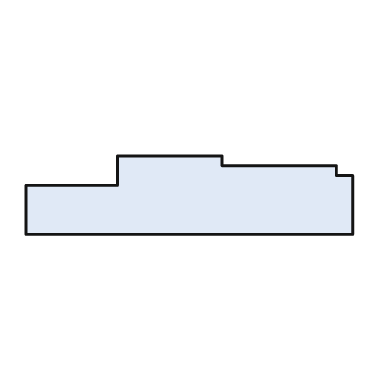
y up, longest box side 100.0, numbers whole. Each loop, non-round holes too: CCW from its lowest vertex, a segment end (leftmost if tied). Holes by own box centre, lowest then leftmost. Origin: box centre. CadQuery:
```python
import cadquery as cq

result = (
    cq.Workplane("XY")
    .moveTo(-50.0, -12.0)
    .lineTo(50.0, -12.0)
    .lineTo(50.0, 6.0)
    .lineTo(45.0, 6.0)
    .lineTo(45.0, 9.0)
    .lineTo(10.0, 9.0)
    .lineTo(10.0, 12.0)
    .lineTo(-22.0, 12.0)
    .lineTo(-22.0, 3.0)
    .lineTo(-50.0, 3.0)
    .close()
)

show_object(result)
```